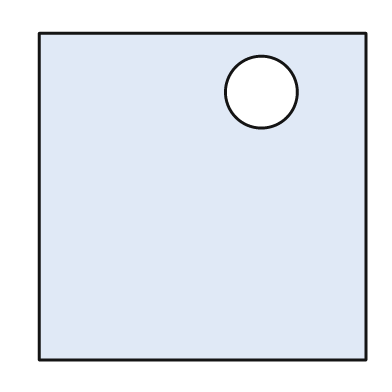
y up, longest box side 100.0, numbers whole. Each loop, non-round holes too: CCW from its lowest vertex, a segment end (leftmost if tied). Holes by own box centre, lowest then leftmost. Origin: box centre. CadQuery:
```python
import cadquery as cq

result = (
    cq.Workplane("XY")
    .moveTo(-50.0, -50.0)
    .lineTo(50.0, -50.0)
    .lineTo(50.0, 50.0)
    .lineTo(-50.0, 50.0)
    .close()
    .moveTo(18.0, 32.0)
    .circle(11.0)
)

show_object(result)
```